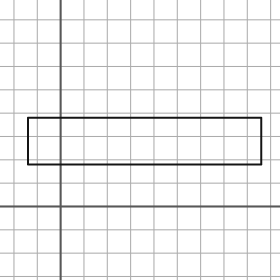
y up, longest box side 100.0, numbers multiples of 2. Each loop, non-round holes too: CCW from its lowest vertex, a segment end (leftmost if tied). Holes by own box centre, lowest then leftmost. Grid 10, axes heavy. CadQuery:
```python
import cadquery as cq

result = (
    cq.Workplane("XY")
    .moveTo(-14.0, 18.0)
    .lineTo(86.0, 18.0)
    .lineTo(86.0, 38.0)
    .lineTo(-14.0, 38.0)
    .close()
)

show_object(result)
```